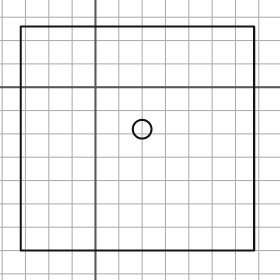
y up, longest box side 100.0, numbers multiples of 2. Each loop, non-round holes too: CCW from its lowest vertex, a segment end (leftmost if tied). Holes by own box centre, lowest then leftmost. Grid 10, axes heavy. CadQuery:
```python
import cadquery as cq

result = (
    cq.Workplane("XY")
    .moveTo(-32.0, -70.0)
    .lineTo(68.0, -70.0)
    .lineTo(68.0, 26.0)
    .lineTo(-32.0, 26.0)
    .close()
    .moveTo(20.0, -18.0)
    .circle(4.0)
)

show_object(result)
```